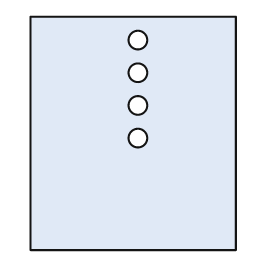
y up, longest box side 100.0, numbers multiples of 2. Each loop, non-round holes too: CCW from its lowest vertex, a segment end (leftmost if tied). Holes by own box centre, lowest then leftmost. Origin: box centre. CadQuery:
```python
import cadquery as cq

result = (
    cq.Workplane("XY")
    .moveTo(-44.0, -50.0)
    .lineTo(44.0, -50.0)
    .lineTo(44.0, 50.0)
    .lineTo(-44.0, 50.0)
    .close()
    .moveTo(2.0, -2.0)
    .circle(4.0)
    .moveTo(2.0, 12.0)
    .circle(4.0)
    .moveTo(2.0, 26.0)
    .circle(4.0)
    .moveTo(2.0, 40.0)
    .circle(4.0)
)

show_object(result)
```